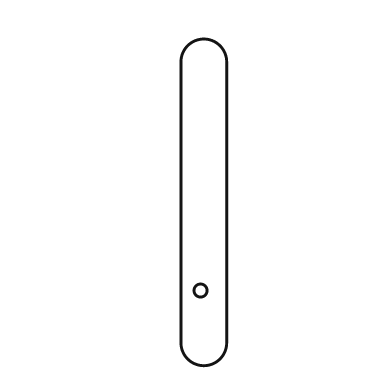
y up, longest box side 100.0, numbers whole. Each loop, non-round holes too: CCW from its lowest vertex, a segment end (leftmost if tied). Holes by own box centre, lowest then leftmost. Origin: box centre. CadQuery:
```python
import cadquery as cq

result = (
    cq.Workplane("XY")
    .moveTo(-7.0, -43.0)
    .threePointArc((0.0, -50.0), (7.0, -43.0))
    .lineTo(7.0, 43.0)
    .threePointArc((0.0, 50.0), (-7.0, 43.0))
    .close()
    .moveTo(-1.0, -27.0)
    .circle(2.0)
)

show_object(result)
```